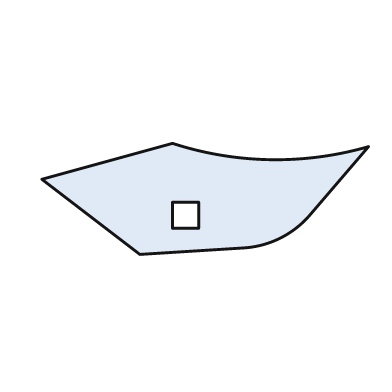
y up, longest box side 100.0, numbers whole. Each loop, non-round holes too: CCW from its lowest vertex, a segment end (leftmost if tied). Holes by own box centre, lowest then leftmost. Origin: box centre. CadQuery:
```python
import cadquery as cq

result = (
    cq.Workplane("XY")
    .moveTo(-20.0, -17.0)
    .lineTo(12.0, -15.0)
    .threePointArc((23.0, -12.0), (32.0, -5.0))
    .lineTo(50.0, 16.0)
    .threePointArc((20.0, 12.0), (-10.0, 17.0))
    .lineTo(-50.0, 6.0)
    .close()
    .moveTo(-10.0, -9.0)
    .lineTo(-2.0, -9.0)
    .lineTo(-2.0, -1.0)
    .lineTo(-10.0, -1.0)
    .close()
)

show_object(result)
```